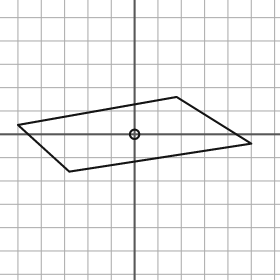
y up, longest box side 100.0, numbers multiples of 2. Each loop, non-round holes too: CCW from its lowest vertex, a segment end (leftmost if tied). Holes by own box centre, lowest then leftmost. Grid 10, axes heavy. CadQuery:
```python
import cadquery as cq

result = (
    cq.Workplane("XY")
    .moveTo(-28.0, -16.0)
    .lineTo(50.0, -4.0)
    .lineTo(18.0, 16.0)
    .lineTo(-50.0, 4.0)
    .close()
    .moveTo(0.0, 0.0)
    .circle(2.0)
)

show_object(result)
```